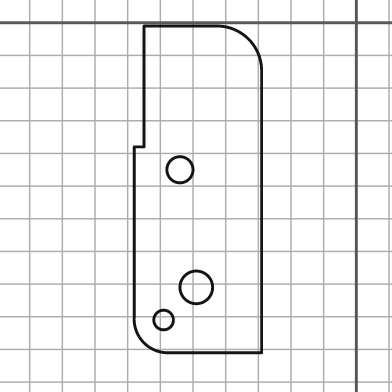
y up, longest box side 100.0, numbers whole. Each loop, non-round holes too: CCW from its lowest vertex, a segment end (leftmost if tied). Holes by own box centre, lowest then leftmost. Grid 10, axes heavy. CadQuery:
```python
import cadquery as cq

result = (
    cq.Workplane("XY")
    .moveTo(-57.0, -101.0)
    .lineTo(-29.0, -101.0)
    .lineTo(-29.0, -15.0)
    .threePointArc((-33.0, -5.0), (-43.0, -1.0))
    .lineTo(-65.0, -1.0)
    .lineTo(-65.0, -38.0)
    .lineTo(-68.0, -38.0)
    .lineTo(-68.0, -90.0)
    .threePointArc((-65.0, -98.0), (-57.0, -101.0))
    .close()
    .moveTo(-59.0, -91.0)
    .circle(3.0)
    .moveTo(-49.0, -81.0)
    .circle(5.0)
    .moveTo(-54.0, -45.0)
    .circle(4.0)
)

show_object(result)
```